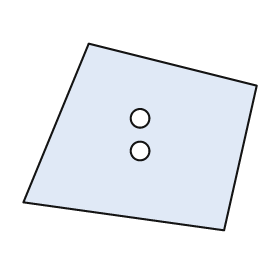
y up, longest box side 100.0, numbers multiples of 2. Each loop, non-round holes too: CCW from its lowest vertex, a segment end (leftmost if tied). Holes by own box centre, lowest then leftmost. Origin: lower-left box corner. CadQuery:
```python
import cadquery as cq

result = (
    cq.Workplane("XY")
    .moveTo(86.0, 0.0)
    .lineTo(100.0, 62.0)
    .lineTo(28.0, 80.0)
    .lineTo(0.0, 12.0)
    .close()
    .moveTo(50.0, 34.0)
    .circle(4.0)
    .moveTo(50.0, 48.0)
    .circle(4.0)
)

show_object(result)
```